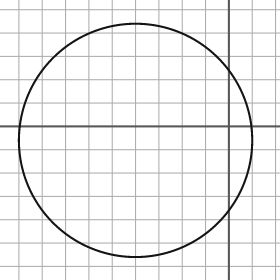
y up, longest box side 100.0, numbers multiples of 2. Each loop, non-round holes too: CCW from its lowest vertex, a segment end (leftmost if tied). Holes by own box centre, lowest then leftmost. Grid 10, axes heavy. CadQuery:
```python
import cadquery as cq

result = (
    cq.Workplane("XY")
    .moveTo(-40.0, -6.0)
    .circle(50.0)
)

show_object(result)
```